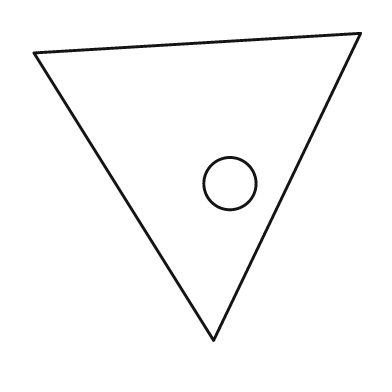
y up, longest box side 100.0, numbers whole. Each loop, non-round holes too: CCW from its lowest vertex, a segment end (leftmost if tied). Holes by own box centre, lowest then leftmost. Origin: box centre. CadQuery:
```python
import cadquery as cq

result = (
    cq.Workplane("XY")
    .moveTo(5.0, -47.0)
    .lineTo(50.0, 47.0)
    .lineTo(-50.0, 41.0)
    .close()
    .moveTo(10.0, 1.0)
    .circle(8.0)
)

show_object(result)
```